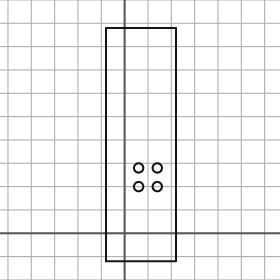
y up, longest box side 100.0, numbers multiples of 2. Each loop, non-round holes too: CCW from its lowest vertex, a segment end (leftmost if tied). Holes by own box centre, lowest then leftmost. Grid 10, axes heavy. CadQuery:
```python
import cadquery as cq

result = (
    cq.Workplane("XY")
    .moveTo(-8.0, -12.0)
    .lineTo(22.0, -12.0)
    .lineTo(22.0, 88.0)
    .lineTo(-8.0, 88.0)
    .close()
    .moveTo(6.0, 20.0)
    .circle(2.0)
    .moveTo(14.0, 20.0)
    .circle(2.0)
    .moveTo(6.0, 28.0)
    .circle(2.0)
    .moveTo(14.0, 28.0)
    .circle(2.0)
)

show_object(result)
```